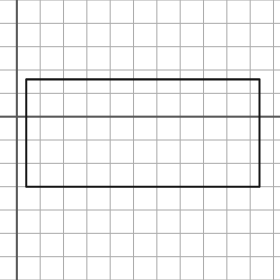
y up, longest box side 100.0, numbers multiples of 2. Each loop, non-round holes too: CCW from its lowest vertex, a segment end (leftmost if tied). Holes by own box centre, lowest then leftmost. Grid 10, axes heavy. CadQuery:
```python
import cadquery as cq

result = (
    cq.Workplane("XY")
    .moveTo(4.0, -30.0)
    .lineTo(104.0, -30.0)
    .lineTo(104.0, 16.0)
    .lineTo(4.0, 16.0)
    .close()
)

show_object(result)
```